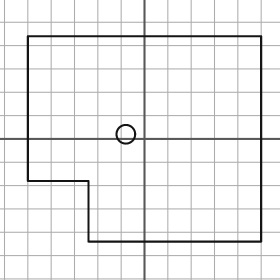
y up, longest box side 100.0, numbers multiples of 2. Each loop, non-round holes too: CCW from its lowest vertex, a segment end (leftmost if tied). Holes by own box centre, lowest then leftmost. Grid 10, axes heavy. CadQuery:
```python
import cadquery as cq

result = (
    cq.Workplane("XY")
    .moveTo(-24.0, -44.0)
    .lineTo(50.0, -44.0)
    .lineTo(50.0, 44.0)
    .lineTo(-50.0, 44.0)
    .lineTo(-50.0, -18.0)
    .lineTo(-24.0, -18.0)
    .close()
    .moveTo(-8.0, 2.0)
    .circle(4.0)
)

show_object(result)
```